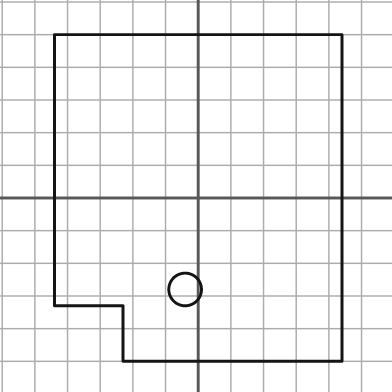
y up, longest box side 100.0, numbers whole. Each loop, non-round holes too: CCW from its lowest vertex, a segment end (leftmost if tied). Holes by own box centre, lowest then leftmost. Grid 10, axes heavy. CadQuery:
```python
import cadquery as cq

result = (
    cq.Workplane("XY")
    .moveTo(-23.0, -50.0)
    .lineTo(44.0, -50.0)
    .lineTo(44.0, 50.0)
    .lineTo(-44.0, 50.0)
    .lineTo(-44.0, -33.0)
    .lineTo(-23.0, -33.0)
    .close()
    .moveTo(-4.0, -28.0)
    .circle(5.0)
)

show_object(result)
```